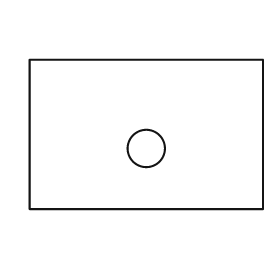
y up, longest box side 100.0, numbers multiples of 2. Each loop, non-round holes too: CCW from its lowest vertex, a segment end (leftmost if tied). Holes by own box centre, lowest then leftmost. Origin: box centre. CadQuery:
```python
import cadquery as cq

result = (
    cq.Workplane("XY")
    .moveTo(-50.0, -32.0)
    .lineTo(50.0, -32.0)
    .lineTo(50.0, 32.0)
    .lineTo(-50.0, 32.0)
    .close()
    .moveTo(0.0, -6.0)
    .circle(8.0)
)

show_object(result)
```